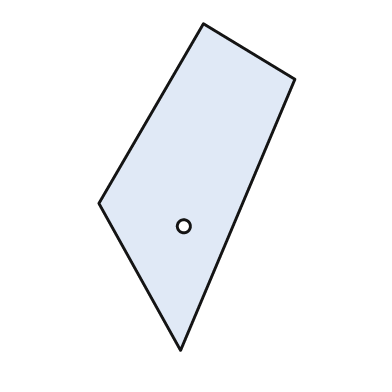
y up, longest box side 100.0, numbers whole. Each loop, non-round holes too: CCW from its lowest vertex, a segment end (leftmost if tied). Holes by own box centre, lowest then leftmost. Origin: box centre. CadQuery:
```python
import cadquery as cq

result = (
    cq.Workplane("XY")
    .moveTo(-5.0, -50.0)
    .lineTo(30.0, 33.0)
    .lineTo(2.0, 50.0)
    .lineTo(-30.0, -5.0)
    .close()
    .moveTo(-4.0, -12.0)
    .circle(2.0)
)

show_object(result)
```